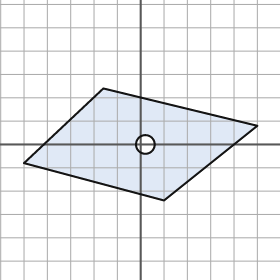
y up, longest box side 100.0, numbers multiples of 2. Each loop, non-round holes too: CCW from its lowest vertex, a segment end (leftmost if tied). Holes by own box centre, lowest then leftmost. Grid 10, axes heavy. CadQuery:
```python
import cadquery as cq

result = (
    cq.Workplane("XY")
    .moveTo(10.0, -24.0)
    .lineTo(50.0, 8.0)
    .lineTo(-16.0, 24.0)
    .lineTo(-50.0, -8.0)
    .close()
    .moveTo(2.0, 0.0)
    .circle(4.0)
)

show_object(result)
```